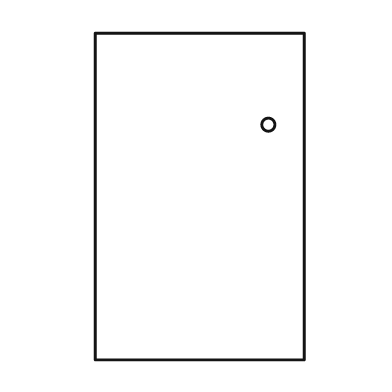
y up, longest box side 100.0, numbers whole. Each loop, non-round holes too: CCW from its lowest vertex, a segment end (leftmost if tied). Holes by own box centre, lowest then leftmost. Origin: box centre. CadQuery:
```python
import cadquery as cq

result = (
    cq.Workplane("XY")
    .moveTo(-32.0, -50.0)
    .lineTo(32.0, -50.0)
    .lineTo(32.0, 50.0)
    .lineTo(-32.0, 50.0)
    .close()
    .moveTo(21.0, 22.0)
    .circle(2.0)
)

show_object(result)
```